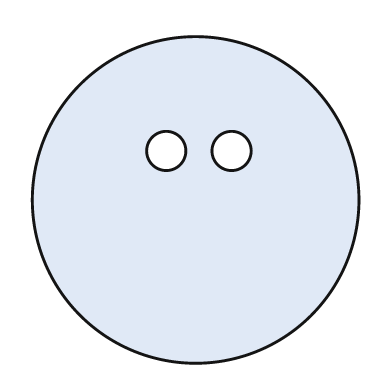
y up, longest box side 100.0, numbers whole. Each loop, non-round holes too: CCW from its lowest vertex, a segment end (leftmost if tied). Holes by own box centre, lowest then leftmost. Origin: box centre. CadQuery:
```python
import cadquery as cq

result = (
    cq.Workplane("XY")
    .moveTo(0.0, 0.0)
    .circle(50.0)
    .moveTo(-9.0, 15.0)
    .circle(6.0)
    .moveTo(11.0, 15.0)
    .circle(6.0)
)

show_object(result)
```